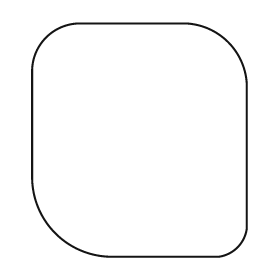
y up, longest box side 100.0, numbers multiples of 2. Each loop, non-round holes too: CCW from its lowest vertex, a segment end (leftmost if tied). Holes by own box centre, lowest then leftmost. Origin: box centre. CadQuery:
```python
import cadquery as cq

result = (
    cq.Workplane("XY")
    .moveTo(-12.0, -50.0)
    .lineTo(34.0, -50.0)
    .threePointArc((42.0, -46.0), (46.0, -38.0))
    .lineTo(46.0, 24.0)
    .threePointArc((38.0, 42.0), (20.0, 50.0))
    .lineTo(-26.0, 50.0)
    .threePointArc((-40.0, 44.0), (-46.0, 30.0))
    .lineTo(-46.0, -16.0)
    .threePointArc((-36.0, -40.0), (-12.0, -50.0))
    .close()
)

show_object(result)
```